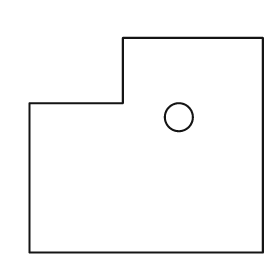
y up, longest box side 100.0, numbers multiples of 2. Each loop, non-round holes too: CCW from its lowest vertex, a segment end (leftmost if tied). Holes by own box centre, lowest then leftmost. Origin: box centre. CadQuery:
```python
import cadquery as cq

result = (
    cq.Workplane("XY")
    .moveTo(-50.0, -46.0)
    .lineTo(50.0, -46.0)
    .lineTo(50.0, 46.0)
    .lineTo(-10.0, 46.0)
    .lineTo(-10.0, 18.0)
    .lineTo(-50.0, 18.0)
    .close()
    .moveTo(14.0, 12.0)
    .circle(6.0)
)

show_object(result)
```